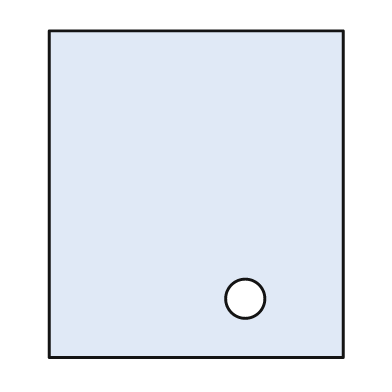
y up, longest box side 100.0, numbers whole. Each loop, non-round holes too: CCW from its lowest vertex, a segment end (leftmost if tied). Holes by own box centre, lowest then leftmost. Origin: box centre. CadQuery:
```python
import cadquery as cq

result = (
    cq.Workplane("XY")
    .moveTo(-45.0, -50.0)
    .lineTo(45.0, -50.0)
    .lineTo(45.0, 50.0)
    .lineTo(-45.0, 50.0)
    .close()
    .moveTo(15.0, -32.0)
    .circle(6.0)
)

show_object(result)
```